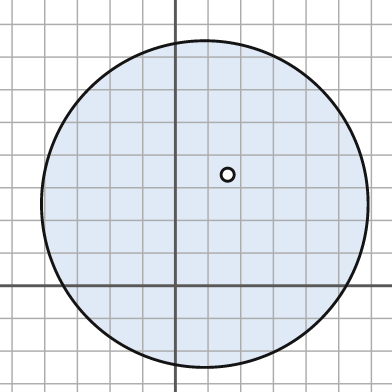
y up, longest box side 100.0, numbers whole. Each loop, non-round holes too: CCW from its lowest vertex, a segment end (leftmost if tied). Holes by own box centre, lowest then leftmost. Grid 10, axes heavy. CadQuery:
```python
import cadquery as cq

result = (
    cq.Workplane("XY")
    .moveTo(9.0, 25.0)
    .circle(50.0)
    .moveTo(16.0, 34.0)
    .circle(2.0)
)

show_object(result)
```